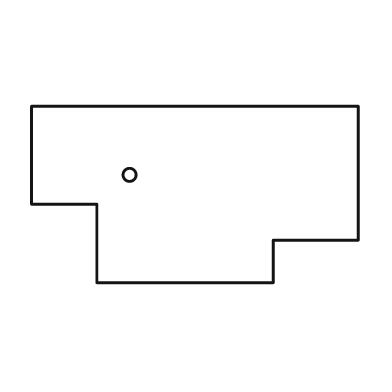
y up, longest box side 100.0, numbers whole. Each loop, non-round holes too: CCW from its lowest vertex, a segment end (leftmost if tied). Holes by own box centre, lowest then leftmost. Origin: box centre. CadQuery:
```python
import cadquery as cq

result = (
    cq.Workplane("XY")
    .moveTo(-30.0, -27.0)
    .lineTo(24.0, -27.0)
    .lineTo(24.0, -14.0)
    .lineTo(50.0, -14.0)
    .lineTo(50.0, 27.0)
    .lineTo(-50.0, 27.0)
    .lineTo(-50.0, -3.0)
    .lineTo(-30.0, -3.0)
    .close()
    .moveTo(-20.0, 6.0)
    .circle(2.0)
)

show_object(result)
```